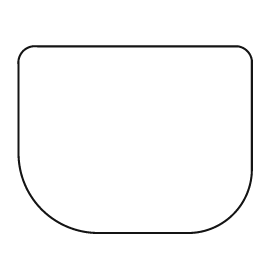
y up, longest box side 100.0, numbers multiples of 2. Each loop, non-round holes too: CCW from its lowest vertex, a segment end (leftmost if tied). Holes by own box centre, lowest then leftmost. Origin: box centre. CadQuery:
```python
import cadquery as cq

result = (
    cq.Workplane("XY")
    .moveTo(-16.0, -40.0)
    .lineTo(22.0, -40.0)
    .threePointArc((42.0, -32.0), (50.0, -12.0))
    .lineTo(50.0, 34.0)
    .threePointArc((48.0, 38.0), (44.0, 40.0))
    .lineTo(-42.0, 40.0)
    .threePointArc((-48.0, 38.0), (-50.0, 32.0))
    .lineTo(-50.0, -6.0)
    .threePointArc((-40.0, -30.0), (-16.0, -40.0))
    .close()
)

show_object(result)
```